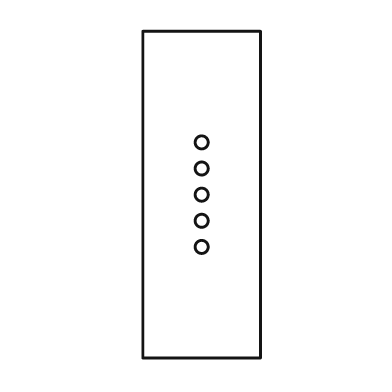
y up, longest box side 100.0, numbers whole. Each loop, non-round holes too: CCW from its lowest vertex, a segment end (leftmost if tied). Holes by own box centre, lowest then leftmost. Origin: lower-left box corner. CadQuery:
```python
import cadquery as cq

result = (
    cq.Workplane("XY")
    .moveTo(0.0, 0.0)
    .lineTo(36.0, 0.0)
    .lineTo(36.0, 100.0)
    .lineTo(0.0, 100.0)
    .close()
    .moveTo(18.0, 34.0)
    .circle(2.0)
    .moveTo(18.0, 42.0)
    .circle(2.0)
    .moveTo(18.0, 50.0)
    .circle(2.0)
    .moveTo(18.0, 58.0)
    .circle(2.0)
    .moveTo(18.0, 66.0)
    .circle(2.0)
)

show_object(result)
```